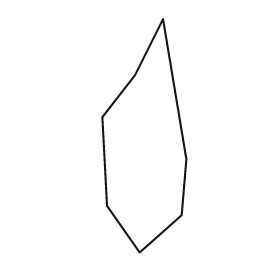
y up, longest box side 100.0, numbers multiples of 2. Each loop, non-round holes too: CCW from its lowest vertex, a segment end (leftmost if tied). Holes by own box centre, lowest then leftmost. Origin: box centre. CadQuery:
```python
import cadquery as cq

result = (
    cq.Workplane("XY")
    .moveTo(-2.0, -50.0)
    .lineTo(16.0, -34.0)
    .lineTo(18.0, -10.0)
    .lineTo(8.0, 50.0)
    .lineTo(-4.0, 26.0)
    .lineTo(-18.0, 8.0)
    .lineTo(-16.0, -30.0)
    .close()
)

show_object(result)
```